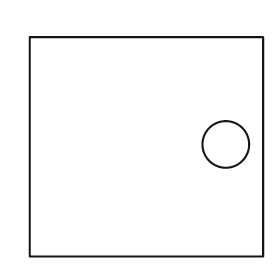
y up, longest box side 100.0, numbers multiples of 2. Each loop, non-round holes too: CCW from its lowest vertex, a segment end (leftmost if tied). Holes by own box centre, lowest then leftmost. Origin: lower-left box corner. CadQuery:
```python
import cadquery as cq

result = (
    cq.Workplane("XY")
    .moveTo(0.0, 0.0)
    .lineTo(100.0, 0.0)
    .lineTo(100.0, 94.0)
    .lineTo(0.0, 94.0)
    .close()
    .moveTo(84.0, 48.0)
    .circle(10.0)
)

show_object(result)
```